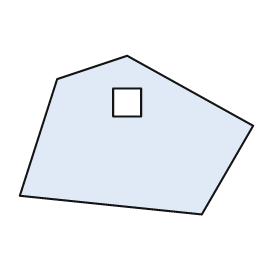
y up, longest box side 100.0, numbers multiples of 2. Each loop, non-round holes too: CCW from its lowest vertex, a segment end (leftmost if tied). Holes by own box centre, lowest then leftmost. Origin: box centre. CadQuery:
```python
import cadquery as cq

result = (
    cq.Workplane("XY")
    .moveTo(28.0, -34.0)
    .lineTo(50.0, 4.0)
    .lineTo(-4.0, 34.0)
    .lineTo(-34.0, 24.0)
    .lineTo(-50.0, -26.0)
    .close()
    .moveTo(-10.0, 8.0)
    .lineTo(2.0, 8.0)
    .lineTo(2.0, 20.0)
    .lineTo(-10.0, 20.0)
    .close()
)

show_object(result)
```